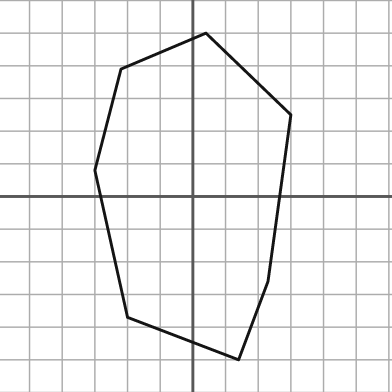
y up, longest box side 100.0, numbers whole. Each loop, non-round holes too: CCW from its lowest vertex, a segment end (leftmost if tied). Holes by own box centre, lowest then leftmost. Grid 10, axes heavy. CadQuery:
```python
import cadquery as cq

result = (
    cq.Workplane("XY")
    .moveTo(14.0, -50.0)
    .lineTo(23.0, -26.0)
    .lineTo(30.0, 25.0)
    .lineTo(4.0, 50.0)
    .lineTo(-22.0, 39.0)
    .lineTo(-30.0, 8.0)
    .lineTo(-20.0, -37.0)
    .close()
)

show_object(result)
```